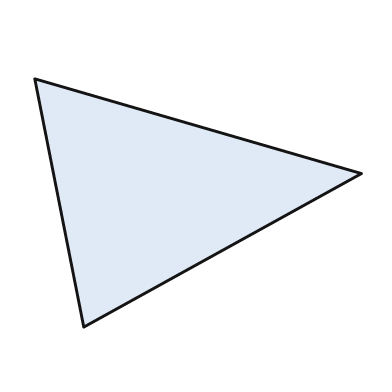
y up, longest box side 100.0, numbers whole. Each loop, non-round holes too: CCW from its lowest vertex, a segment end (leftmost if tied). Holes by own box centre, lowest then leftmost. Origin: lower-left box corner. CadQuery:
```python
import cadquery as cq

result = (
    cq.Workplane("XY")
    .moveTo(15.0, 0.0)
    .lineTo(100.0, 47.0)
    .lineTo(0.0, 76.0)
    .close()
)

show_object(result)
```